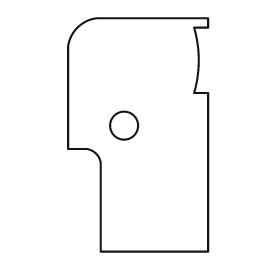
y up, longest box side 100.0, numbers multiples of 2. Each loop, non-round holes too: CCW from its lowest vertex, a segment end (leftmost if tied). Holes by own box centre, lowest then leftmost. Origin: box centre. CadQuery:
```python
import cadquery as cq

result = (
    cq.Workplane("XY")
    .moveTo(-16.0, -50.0)
    .lineTo(30.0, -50.0)
    .lineTo(30.0, 18.0)
    .lineTo(24.0, 18.0)
    .threePointArc((26.0, 32.0), (24.0, 46.0))
    .lineTo(30.0, 46.0)
    .lineTo(30.0, 50.0)
    .lineTo(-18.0, 50.0)
    .threePointArc((-26.0, 46.0), (-30.0, 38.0))
    .lineTo(-30.0, -6.0)
    .lineTo(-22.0, -6.0)
    .threePointArc((-18.0, -8.0), (-16.0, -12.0))
    .close()
    .moveTo(-6.0, 4.0)
    .circle(6.0)
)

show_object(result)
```